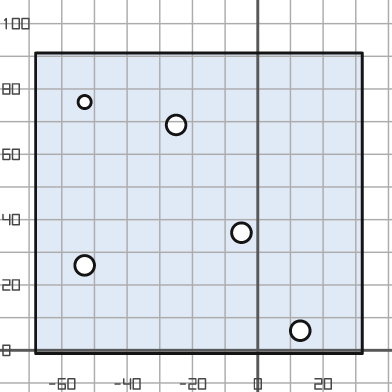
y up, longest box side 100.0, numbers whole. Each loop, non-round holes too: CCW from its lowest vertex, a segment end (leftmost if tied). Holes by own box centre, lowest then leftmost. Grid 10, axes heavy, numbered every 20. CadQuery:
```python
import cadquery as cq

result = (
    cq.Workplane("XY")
    .moveTo(-68.0, -1.0)
    .lineTo(32.0, -1.0)
    .lineTo(32.0, 91.0)
    .lineTo(-68.0, 91.0)
    .close()
    .moveTo(13.0, 6.0)
    .circle(3.0)
    .moveTo(-53.0, 26.0)
    .circle(3.0)
    .moveTo(-5.0, 36.0)
    .circle(3.0)
    .moveTo(-25.0, 69.0)
    .circle(3.0)
    .moveTo(-53.0, 76.0)
    .circle(2.0)
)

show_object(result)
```